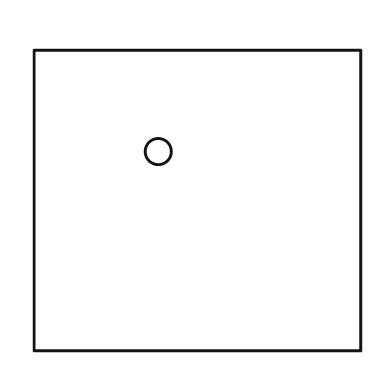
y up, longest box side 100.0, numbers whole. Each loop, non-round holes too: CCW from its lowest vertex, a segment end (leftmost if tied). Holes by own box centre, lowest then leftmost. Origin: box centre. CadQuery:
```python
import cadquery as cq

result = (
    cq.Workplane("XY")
    .moveTo(-50.0, -46.0)
    .lineTo(50.0, -46.0)
    .lineTo(50.0, 46.0)
    .lineTo(-50.0, 46.0)
    .close()
    .moveTo(-12.0, 15.0)
    .circle(4.0)
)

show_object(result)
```